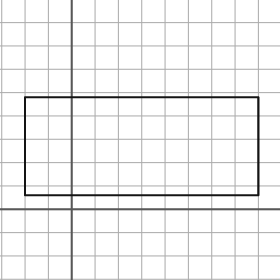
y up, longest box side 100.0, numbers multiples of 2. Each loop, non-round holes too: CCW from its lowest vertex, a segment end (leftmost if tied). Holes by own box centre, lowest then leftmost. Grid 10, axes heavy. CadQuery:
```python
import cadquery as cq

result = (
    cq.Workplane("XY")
    .moveTo(-20.0, 6.0)
    .lineTo(80.0, 6.0)
    .lineTo(80.0, 48.0)
    .lineTo(-20.0, 48.0)
    .close()
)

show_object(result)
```